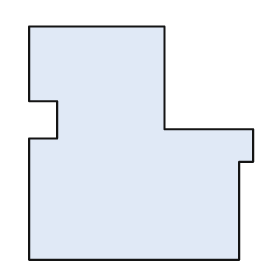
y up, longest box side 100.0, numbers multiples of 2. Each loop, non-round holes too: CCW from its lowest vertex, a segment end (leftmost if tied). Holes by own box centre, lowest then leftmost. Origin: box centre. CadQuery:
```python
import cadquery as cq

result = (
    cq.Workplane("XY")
    .moveTo(-48.0, -50.0)
    .lineTo(42.0, -50.0)
    .lineTo(42.0, -8.0)
    .lineTo(48.0, -8.0)
    .lineTo(48.0, 6.0)
    .lineTo(10.0, 6.0)
    .lineTo(10.0, 50.0)
    .lineTo(-48.0, 50.0)
    .lineTo(-48.0, 18.0)
    .lineTo(-36.0, 18.0)
    .lineTo(-36.0, 2.0)
    .lineTo(-48.0, 2.0)
    .close()
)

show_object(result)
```